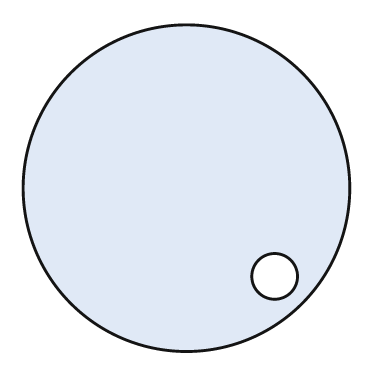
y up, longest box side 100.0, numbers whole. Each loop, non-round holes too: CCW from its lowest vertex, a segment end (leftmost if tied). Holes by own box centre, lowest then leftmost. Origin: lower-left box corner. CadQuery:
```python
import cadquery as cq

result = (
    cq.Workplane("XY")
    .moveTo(50.0, 50.0)
    .circle(50.0)
    .moveTo(77.0, 23.0)
    .circle(7.0)
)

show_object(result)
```